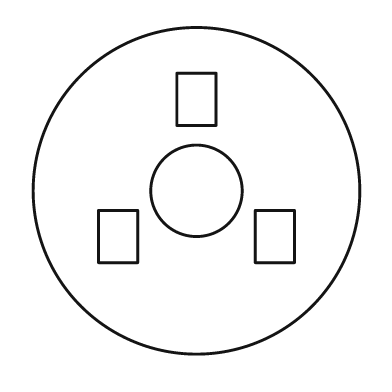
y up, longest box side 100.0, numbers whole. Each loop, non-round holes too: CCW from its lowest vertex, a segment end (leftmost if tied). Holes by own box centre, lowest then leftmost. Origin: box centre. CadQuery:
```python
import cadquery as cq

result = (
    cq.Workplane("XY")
    .moveTo(0.0, 0.0)
    .circle(50.0)
    .moveTo(-30.0, -22.0)
    .lineTo(-18.0, -22.0)
    .lineTo(-18.0, -6.0)
    .lineTo(-30.0, -6.0)
    .close()
    .moveTo(18.0, -22.0)
    .lineTo(30.0, -22.0)
    .lineTo(30.0, -6.0)
    .lineTo(18.0, -6.0)
    .close()
    .moveTo(0.0, 0.0)
    .circle(14.0)
    .moveTo(-6.0, 20.0)
    .lineTo(6.0, 20.0)
    .lineTo(6.0, 36.0)
    .lineTo(-6.0, 36.0)
    .close()
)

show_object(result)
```